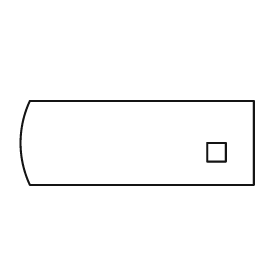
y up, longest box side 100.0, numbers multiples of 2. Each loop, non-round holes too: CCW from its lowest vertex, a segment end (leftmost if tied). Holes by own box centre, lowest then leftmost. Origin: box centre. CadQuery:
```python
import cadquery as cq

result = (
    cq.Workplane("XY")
    .moveTo(-46.0, -18.0)
    .lineTo(50.0, -18.0)
    .lineTo(50.0, 18.0)
    .lineTo(-46.0, 18.0)
    .threePointArc((-50.0, 0.0), (-46.0, -18.0))
    .close()
    .moveTo(30.0, -8.0)
    .lineTo(38.0, -8.0)
    .lineTo(38.0, 0.0)
    .lineTo(30.0, 0.0)
    .close()
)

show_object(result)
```